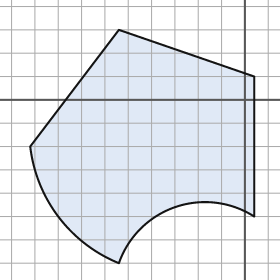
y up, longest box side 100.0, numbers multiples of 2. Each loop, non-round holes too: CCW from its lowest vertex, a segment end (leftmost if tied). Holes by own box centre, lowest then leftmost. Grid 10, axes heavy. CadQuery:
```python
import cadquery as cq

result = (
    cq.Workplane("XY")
    .moveTo(-54.0, -70.0)
    .threePointArc((-30.0, -46.0), (4.0, -50.0))
    .lineTo(4.0, 10.0)
    .lineTo(-54.0, 30.0)
    .lineTo(-92.0, -20.0)
    .threePointArc((-80.0, -50.0), (-54.0, -70.0))
    .close()
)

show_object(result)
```